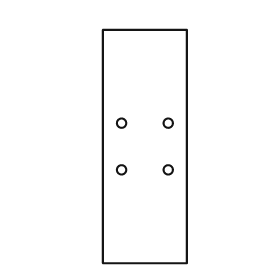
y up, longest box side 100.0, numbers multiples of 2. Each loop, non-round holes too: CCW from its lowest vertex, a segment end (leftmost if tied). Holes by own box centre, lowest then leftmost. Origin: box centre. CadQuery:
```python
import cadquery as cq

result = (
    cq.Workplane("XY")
    .moveTo(-18.0, -50.0)
    .lineTo(18.0, -50.0)
    .lineTo(18.0, 50.0)
    .lineTo(-18.0, 50.0)
    .close()
    .moveTo(-10.0, -10.0)
    .circle(2.0)
    .moveTo(10.0, -10.0)
    .circle(2.0)
    .moveTo(-10.0, 10.0)
    .circle(2.0)
    .moveTo(10.0, 10.0)
    .circle(2.0)
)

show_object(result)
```